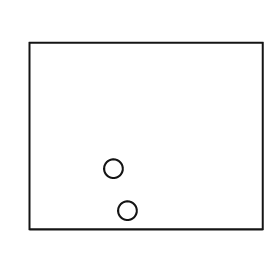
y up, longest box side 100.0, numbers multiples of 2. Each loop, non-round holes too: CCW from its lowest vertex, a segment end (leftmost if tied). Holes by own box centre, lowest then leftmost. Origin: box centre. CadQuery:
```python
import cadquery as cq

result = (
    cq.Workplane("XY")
    .moveTo(-50.0, -40.0)
    .lineTo(50.0, -40.0)
    .lineTo(50.0, 40.0)
    .lineTo(-50.0, 40.0)
    .close()
    .moveTo(-8.0, -32.0)
    .circle(4.0)
    .moveTo(-14.0, -14.0)
    .circle(4.0)
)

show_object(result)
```